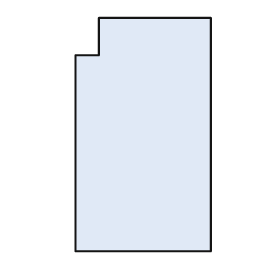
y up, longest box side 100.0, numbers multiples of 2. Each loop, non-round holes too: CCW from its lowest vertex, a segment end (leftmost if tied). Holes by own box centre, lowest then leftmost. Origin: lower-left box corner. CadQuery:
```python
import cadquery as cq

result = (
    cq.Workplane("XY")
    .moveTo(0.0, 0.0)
    .lineTo(58.0, 0.0)
    .lineTo(58.0, 100.0)
    .lineTo(10.0, 100.0)
    .lineTo(10.0, 84.0)
    .lineTo(0.0, 84.0)
    .close()
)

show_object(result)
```